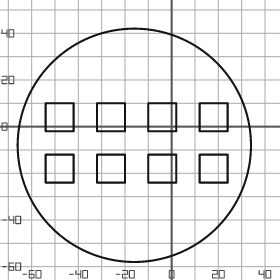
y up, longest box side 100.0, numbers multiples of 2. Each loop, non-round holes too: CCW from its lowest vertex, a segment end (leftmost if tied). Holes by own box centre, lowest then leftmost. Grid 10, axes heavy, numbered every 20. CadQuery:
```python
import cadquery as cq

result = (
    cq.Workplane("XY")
    .moveTo(-16.0, -8.0)
    .circle(50.0)
    .moveTo(-54.0, -24.0)
    .lineTo(-42.0, -24.0)
    .lineTo(-42.0, -12.0)
    .lineTo(-54.0, -12.0)
    .close()
    .moveTo(-32.0, -24.0)
    .lineTo(-20.0, -24.0)
    .lineTo(-20.0, -12.0)
    .lineTo(-32.0, -12.0)
    .close()
    .moveTo(-10.0, -24.0)
    .lineTo(2.0, -24.0)
    .lineTo(2.0, -12.0)
    .lineTo(-10.0, -12.0)
    .close()
    .moveTo(12.0, -24.0)
    .lineTo(24.0, -24.0)
    .lineTo(24.0, -12.0)
    .lineTo(12.0, -12.0)
    .close()
    .moveTo(-54.0, -2.0)
    .lineTo(-42.0, -2.0)
    .lineTo(-42.0, 10.0)
    .lineTo(-54.0, 10.0)
    .close()
    .moveTo(-32.0, -2.0)
    .lineTo(-20.0, -2.0)
    .lineTo(-20.0, 10.0)
    .lineTo(-32.0, 10.0)
    .close()
    .moveTo(-10.0, -2.0)
    .lineTo(2.0, -2.0)
    .lineTo(2.0, 10.0)
    .lineTo(-10.0, 10.0)
    .close()
    .moveTo(12.0, -2.0)
    .lineTo(24.0, -2.0)
    .lineTo(24.0, 10.0)
    .lineTo(12.0, 10.0)
    .close()
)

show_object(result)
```